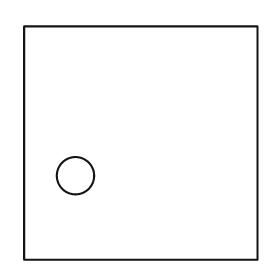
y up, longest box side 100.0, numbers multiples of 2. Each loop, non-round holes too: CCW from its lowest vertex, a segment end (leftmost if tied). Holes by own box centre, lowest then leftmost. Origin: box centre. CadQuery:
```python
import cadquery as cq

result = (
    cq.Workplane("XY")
    .moveTo(-50.0, -50.0)
    .lineTo(50.0, -50.0)
    .lineTo(50.0, 50.0)
    .lineTo(-50.0, 50.0)
    .close()
    .moveTo(-28.0, -14.0)
    .circle(8.0)
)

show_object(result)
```